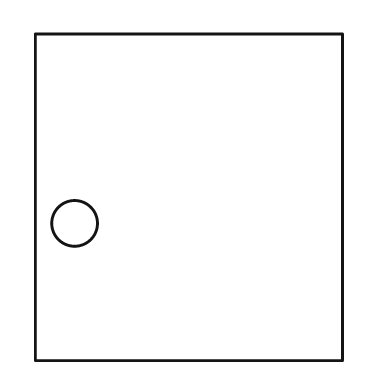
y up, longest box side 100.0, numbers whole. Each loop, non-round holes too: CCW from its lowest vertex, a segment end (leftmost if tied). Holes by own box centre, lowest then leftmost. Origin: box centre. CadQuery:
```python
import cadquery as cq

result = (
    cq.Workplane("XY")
    .moveTo(-47.0, -50.0)
    .lineTo(47.0, -50.0)
    .lineTo(47.0, 50.0)
    .lineTo(-47.0, 50.0)
    .close()
    .moveTo(-35.0, -8.0)
    .circle(7.0)
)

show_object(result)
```